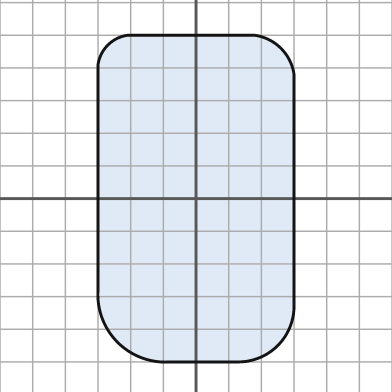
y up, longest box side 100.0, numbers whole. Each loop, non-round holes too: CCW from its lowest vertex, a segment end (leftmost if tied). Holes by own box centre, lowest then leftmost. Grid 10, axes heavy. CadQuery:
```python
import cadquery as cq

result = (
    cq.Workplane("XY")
    .moveTo(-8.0, -50.0)
    .lineTo(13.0, -50.0)
    .threePointArc((25.0, -45.0), (30.0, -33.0))
    .lineTo(30.0, 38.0)
    .threePointArc((26.0, 46.0), (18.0, 50.0))
    .lineTo(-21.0, 50.0)
    .threePointArc((-27.0, 47.0), (-30.0, 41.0))
    .lineTo(-30.0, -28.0)
    .threePointArc((-24.0, -44.0), (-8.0, -50.0))
    .close()
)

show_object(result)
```